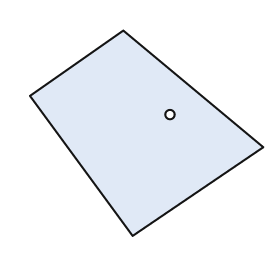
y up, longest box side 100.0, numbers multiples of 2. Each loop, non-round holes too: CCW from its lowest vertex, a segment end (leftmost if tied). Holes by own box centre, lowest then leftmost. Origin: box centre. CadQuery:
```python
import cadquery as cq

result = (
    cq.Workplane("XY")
    .moveTo(-6.0, -44.0)
    .lineTo(50.0, -6.0)
    .lineTo(-10.0, 44.0)
    .lineTo(-50.0, 16.0)
    .close()
    .moveTo(10.0, 8.0)
    .circle(2.0)
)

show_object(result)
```